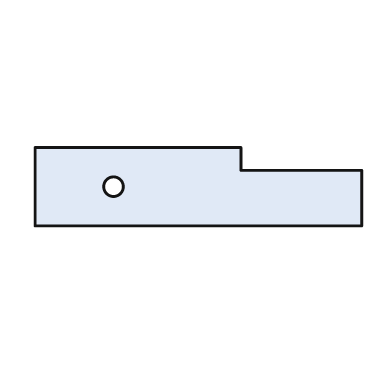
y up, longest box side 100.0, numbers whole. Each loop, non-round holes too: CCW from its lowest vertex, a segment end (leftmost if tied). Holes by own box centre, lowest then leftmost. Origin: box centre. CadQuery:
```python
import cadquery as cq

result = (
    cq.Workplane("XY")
    .moveTo(-50.0, -12.0)
    .lineTo(50.0, -12.0)
    .lineTo(50.0, 5.0)
    .lineTo(13.0, 5.0)
    .lineTo(13.0, 12.0)
    .lineTo(-50.0, 12.0)
    .close()
    .moveTo(-26.0, 0.0)
    .circle(3.0)
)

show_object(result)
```